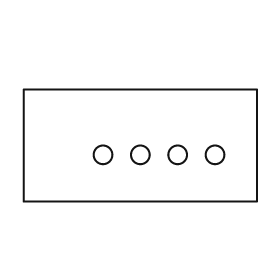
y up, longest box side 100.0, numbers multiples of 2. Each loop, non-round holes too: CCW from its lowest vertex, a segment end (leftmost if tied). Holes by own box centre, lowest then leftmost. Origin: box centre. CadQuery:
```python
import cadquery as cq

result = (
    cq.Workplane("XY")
    .moveTo(-50.0, -24.0)
    .lineTo(50.0, -24.0)
    .lineTo(50.0, 24.0)
    .lineTo(-50.0, 24.0)
    .close()
    .moveTo(-16.0, -4.0)
    .circle(4.0)
    .moveTo(0.0, -4.0)
    .circle(4.0)
    .moveTo(16.0, -4.0)
    .circle(4.0)
    .moveTo(32.0, -4.0)
    .circle(4.0)
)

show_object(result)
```